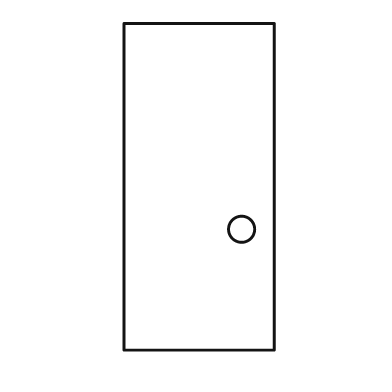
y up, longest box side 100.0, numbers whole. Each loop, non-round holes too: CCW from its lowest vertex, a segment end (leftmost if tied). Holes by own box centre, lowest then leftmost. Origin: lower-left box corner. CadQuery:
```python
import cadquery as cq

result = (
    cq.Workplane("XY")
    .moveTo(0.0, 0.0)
    .lineTo(46.0, 0.0)
    .lineTo(46.0, 100.0)
    .lineTo(0.0, 100.0)
    .close()
    .moveTo(36.0, 37.0)
    .circle(4.0)
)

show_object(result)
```